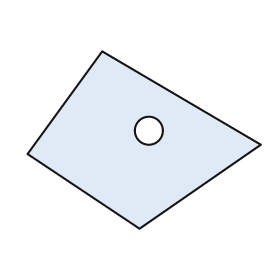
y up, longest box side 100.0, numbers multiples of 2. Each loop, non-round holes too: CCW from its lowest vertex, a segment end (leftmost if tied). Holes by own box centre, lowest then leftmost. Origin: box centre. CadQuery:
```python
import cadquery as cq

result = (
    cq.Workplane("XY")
    .moveTo(-2.0, -38.0)
    .lineTo(50.0, -2.0)
    .lineTo(-18.0, 38.0)
    .lineTo(-50.0, -6.0)
    .close()
    .moveTo(2.0, 4.0)
    .circle(6.0)
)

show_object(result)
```